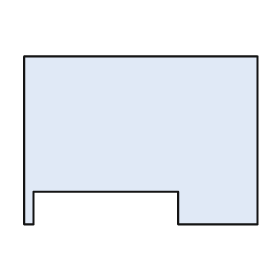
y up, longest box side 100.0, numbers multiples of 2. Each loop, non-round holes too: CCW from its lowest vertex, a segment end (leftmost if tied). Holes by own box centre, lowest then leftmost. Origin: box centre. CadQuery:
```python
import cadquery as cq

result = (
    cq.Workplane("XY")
    .moveTo(-50.0, -36.0)
    .lineTo(-46.0, -36.0)
    .lineTo(-46.0, -22.0)
    .lineTo(16.0, -22.0)
    .lineTo(16.0, -36.0)
    .lineTo(50.0, -36.0)
    .lineTo(50.0, 36.0)
    .lineTo(-50.0, 36.0)
    .close()
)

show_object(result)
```